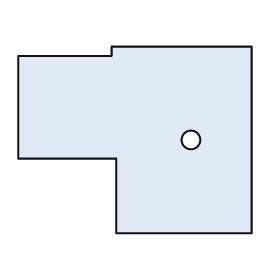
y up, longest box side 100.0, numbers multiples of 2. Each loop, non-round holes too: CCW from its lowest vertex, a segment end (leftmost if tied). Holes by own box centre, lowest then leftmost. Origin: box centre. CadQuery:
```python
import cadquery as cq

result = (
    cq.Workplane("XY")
    .moveTo(-8.0, -40.0)
    .lineTo(50.0, -40.0)
    .lineTo(50.0, 40.0)
    .lineTo(-10.0, 40.0)
    .lineTo(-10.0, 36.0)
    .lineTo(-50.0, 36.0)
    .lineTo(-50.0, -8.0)
    .lineTo(-8.0, -8.0)
    .close()
    .moveTo(24.0, 0.0)
    .circle(4.0)
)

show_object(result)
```